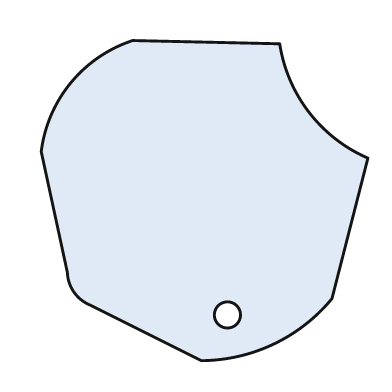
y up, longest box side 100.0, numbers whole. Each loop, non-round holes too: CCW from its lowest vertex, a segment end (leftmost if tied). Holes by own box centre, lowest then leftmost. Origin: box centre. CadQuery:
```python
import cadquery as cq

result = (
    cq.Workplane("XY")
    .moveTo(-1.0, -49.0)
    .threePointArc((21.0, -44.0), (39.0, -30.0))
    .lineTo(50.0, 13.0)
    .threePointArc((32.0, 27.0), (23.0, 48.0))
    .lineTo(-22.0, 49.0)
    .threePointArc((-41.0, 36.0), (-50.0, 15.0))
    .lineTo(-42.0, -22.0)
    .threePointArc((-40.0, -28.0), (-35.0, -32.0))
    .close()
    .moveTo(7.0, -35.0)
    .circle(4.0)
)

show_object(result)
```